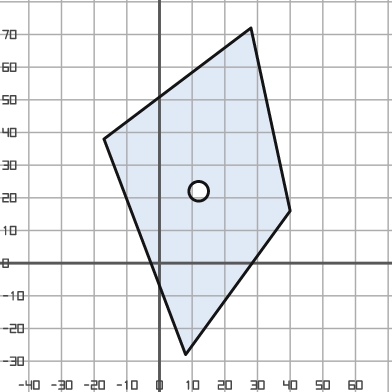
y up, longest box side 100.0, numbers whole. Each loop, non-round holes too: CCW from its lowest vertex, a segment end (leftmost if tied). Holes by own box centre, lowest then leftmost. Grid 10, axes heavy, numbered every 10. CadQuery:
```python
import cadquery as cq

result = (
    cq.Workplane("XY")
    .moveTo(8.0, -28.0)
    .lineTo(40.0, 16.0)
    .lineTo(28.0, 72.0)
    .lineTo(-17.0, 38.0)
    .close()
    .moveTo(12.0, 22.0)
    .circle(3.0)
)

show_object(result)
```